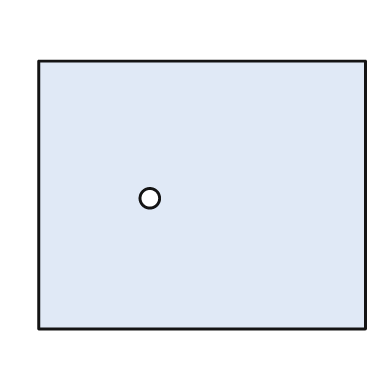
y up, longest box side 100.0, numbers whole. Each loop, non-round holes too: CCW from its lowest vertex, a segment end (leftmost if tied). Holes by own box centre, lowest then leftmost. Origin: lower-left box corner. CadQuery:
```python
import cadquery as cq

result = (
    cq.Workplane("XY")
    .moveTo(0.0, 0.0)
    .lineTo(100.0, 0.0)
    .lineTo(100.0, 82.0)
    .lineTo(0.0, 82.0)
    .close()
    .moveTo(34.0, 40.0)
    .circle(3.0)
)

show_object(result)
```